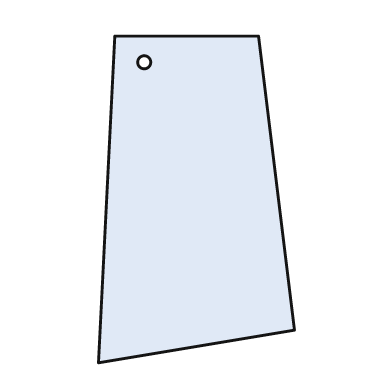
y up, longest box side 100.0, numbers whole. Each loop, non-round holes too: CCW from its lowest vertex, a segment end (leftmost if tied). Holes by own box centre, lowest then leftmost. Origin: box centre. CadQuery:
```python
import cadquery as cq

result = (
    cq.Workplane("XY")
    .moveTo(-30.0, -50.0)
    .lineTo(30.0, -40.0)
    .lineTo(19.0, 50.0)
    .lineTo(-25.0, 50.0)
    .close()
    .moveTo(-16.0, 42.0)
    .circle(2.0)
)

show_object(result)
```